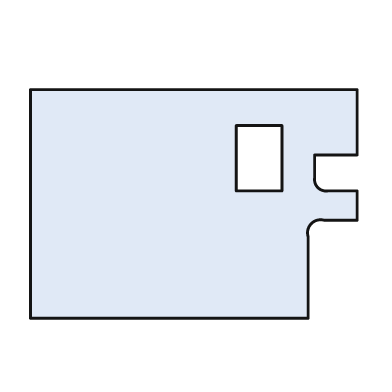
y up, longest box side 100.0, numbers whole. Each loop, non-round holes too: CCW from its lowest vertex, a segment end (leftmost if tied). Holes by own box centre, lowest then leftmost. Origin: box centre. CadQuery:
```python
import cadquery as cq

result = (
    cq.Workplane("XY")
    .moveTo(-50.0, -35.0)
    .lineTo(35.0, -35.0)
    .lineTo(35.0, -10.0)
    .threePointArc((36.0, -6.0), (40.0, -5.0))
    .lineTo(50.0, -5.0)
    .lineTo(50.0, 4.0)
    .lineTo(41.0, 4.0)
    .threePointArc((38.0, 5.0), (37.0, 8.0))
    .lineTo(37.0, 15.0)
    .lineTo(50.0, 15.0)
    .lineTo(50.0, 35.0)
    .lineTo(-50.0, 35.0)
    .close()
    .moveTo(13.0, 4.0)
    .lineTo(27.0, 4.0)
    .lineTo(27.0, 24.0)
    .lineTo(13.0, 24.0)
    .close()
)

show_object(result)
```